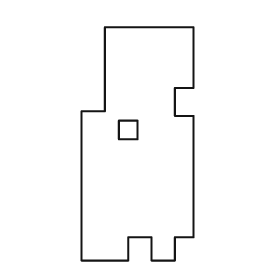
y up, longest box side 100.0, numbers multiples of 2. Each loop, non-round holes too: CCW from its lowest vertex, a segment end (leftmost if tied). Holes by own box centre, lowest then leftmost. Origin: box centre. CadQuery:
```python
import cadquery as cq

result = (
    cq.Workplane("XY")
    .moveTo(-24.0, -50.0)
    .lineTo(-4.0, -50.0)
    .lineTo(-4.0, -40.0)
    .lineTo(6.0, -40.0)
    .lineTo(6.0, -50.0)
    .lineTo(16.0, -50.0)
    .lineTo(16.0, -40.0)
    .lineTo(24.0, -40.0)
    .lineTo(24.0, 12.0)
    .lineTo(16.0, 12.0)
    .lineTo(16.0, 24.0)
    .lineTo(24.0, 24.0)
    .lineTo(24.0, 50.0)
    .lineTo(-14.0, 50.0)
    .lineTo(-14.0, 14.0)
    .lineTo(-24.0, 14.0)
    .close()
    .moveTo(-8.0, 2.0)
    .lineTo(0.0, 2.0)
    .lineTo(0.0, 10.0)
    .lineTo(-8.0, 10.0)
    .close()
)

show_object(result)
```